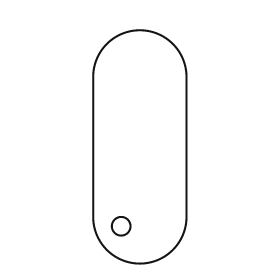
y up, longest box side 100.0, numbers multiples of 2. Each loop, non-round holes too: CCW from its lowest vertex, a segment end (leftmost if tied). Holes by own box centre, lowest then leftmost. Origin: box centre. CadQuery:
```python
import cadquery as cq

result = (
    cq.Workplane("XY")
    .moveTo(-20.0, -30.0)
    .threePointArc((0.0, -50.0), (20.0, -30.0))
    .lineTo(20.0, 30.0)
    .threePointArc((0.0, 50.0), (-20.0, 30.0))
    .close()
    .moveTo(-8.0, -34.0)
    .circle(4.0)
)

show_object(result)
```